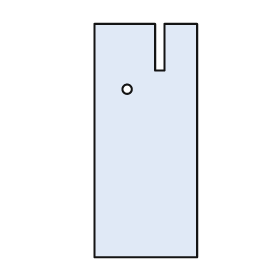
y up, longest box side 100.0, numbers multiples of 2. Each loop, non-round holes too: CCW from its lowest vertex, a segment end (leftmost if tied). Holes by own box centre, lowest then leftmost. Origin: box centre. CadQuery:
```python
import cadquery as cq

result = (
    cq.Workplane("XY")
    .moveTo(-22.0, -50.0)
    .lineTo(22.0, -50.0)
    .lineTo(22.0, 50.0)
    .lineTo(8.0, 50.0)
    .lineTo(8.0, 30.0)
    .lineTo(4.0, 30.0)
    .lineTo(4.0, 50.0)
    .lineTo(-22.0, 50.0)
    .close()
    .moveTo(-8.0, 22.0)
    .circle(2.0)
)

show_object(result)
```